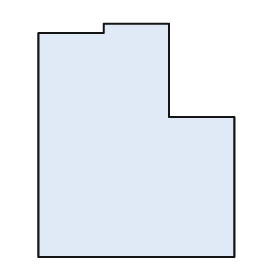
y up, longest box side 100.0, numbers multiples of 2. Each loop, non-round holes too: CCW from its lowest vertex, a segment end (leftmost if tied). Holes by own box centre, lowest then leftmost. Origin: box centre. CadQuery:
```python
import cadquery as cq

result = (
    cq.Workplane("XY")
    .moveTo(-42.0, -50.0)
    .lineTo(42.0, -50.0)
    .lineTo(42.0, 10.0)
    .lineTo(14.0, 10.0)
    .lineTo(14.0, 50.0)
    .lineTo(-14.0, 50.0)
    .lineTo(-14.0, 46.0)
    .lineTo(-42.0, 46.0)
    .close()
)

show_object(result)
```